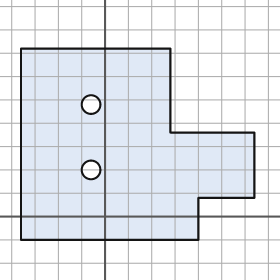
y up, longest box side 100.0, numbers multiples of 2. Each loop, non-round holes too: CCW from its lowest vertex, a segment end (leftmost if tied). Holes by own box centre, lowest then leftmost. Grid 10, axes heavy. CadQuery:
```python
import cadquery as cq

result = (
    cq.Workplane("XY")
    .moveTo(-36.0, -10.0)
    .lineTo(40.0, -10.0)
    .lineTo(40.0, 8.0)
    .lineTo(64.0, 8.0)
    .lineTo(64.0, 36.0)
    .lineTo(28.0, 36.0)
    .lineTo(28.0, 72.0)
    .lineTo(-36.0, 72.0)
    .close()
    .moveTo(-6.0, 20.0)
    .circle(4.0)
    .moveTo(-6.0, 48.0)
    .circle(4.0)
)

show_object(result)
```